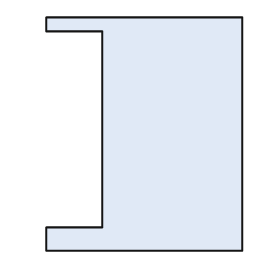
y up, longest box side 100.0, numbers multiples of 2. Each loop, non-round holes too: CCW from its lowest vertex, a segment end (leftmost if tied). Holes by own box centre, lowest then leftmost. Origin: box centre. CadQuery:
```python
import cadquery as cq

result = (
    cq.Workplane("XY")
    .moveTo(-42.0, -50.0)
    .lineTo(42.0, -50.0)
    .lineTo(42.0, 50.0)
    .lineTo(-42.0, 50.0)
    .lineTo(-42.0, 44.0)
    .lineTo(-18.0, 44.0)
    .lineTo(-18.0, -40.0)
    .lineTo(-42.0, -40.0)
    .close()
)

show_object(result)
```